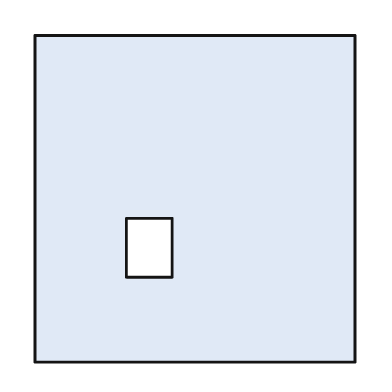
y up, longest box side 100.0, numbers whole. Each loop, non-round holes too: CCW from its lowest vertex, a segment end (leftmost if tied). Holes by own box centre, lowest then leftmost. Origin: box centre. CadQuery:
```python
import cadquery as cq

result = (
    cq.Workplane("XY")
    .moveTo(-49.0, -50.0)
    .lineTo(49.0, -50.0)
    .lineTo(49.0, 50.0)
    .lineTo(-49.0, 50.0)
    .close()
    .moveTo(-21.0, -24.0)
    .lineTo(-7.0, -24.0)
    .lineTo(-7.0, -6.0)
    .lineTo(-21.0, -6.0)
    .close()
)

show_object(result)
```